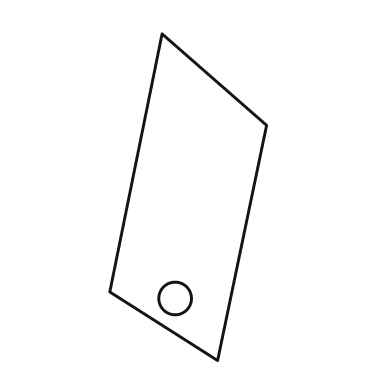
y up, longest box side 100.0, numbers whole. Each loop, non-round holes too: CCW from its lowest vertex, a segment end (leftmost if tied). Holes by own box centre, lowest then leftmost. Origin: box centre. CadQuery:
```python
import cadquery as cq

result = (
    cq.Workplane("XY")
    .moveTo(9.0, -50.0)
    .lineTo(24.0, 22.0)
    .lineTo(-8.0, 50.0)
    .lineTo(-24.0, -29.0)
    .close()
    .moveTo(-4.0, -31.0)
    .circle(5.0)
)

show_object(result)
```